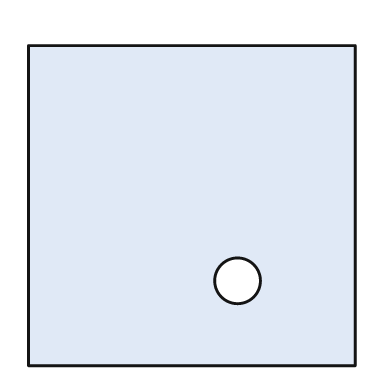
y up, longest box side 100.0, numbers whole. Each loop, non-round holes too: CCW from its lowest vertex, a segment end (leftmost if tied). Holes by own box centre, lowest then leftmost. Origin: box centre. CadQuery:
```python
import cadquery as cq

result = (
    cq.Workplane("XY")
    .moveTo(-50.0, -49.0)
    .lineTo(50.0, -49.0)
    .lineTo(50.0, 49.0)
    .lineTo(-50.0, 49.0)
    .close()
    .moveTo(14.0, -23.0)
    .circle(7.0)
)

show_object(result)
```